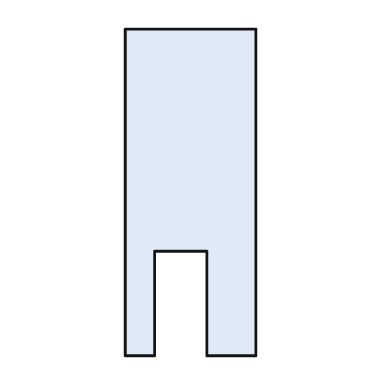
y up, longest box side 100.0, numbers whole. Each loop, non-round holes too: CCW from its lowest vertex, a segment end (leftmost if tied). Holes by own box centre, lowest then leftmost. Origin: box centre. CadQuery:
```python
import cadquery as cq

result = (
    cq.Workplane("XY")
    .moveTo(-20.0, -50.0)
    .lineTo(-11.0, -50.0)
    .lineTo(-11.0, -18.0)
    .lineTo(5.0, -18.0)
    .lineTo(5.0, -50.0)
    .lineTo(20.0, -50.0)
    .lineTo(20.0, 50.0)
    .lineTo(-20.0, 50.0)
    .close()
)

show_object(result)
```